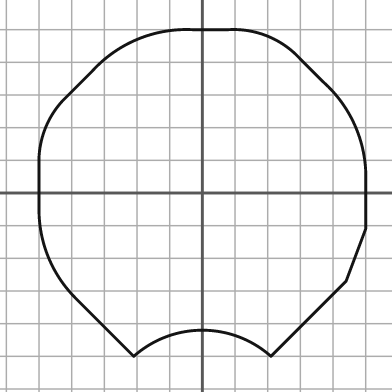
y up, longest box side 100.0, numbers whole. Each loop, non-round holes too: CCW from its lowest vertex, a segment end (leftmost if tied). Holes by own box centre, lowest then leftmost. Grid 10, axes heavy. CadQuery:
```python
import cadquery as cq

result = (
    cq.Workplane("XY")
    .moveTo(-21.0, -50.0)
    .threePointArc((0.0, -42.0), (21.0, -50.0))
    .lineTo(44.0, -27.0)
    .lineTo(50.0, -11.0)
    .lineTo(50.0, 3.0)
    .threePointArc((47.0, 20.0), (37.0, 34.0))
    .lineTo(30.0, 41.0)
    .threePointArc((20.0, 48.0), (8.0, 50.0))
    .lineTo(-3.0, 50.0)
    .threePointArc((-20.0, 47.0), (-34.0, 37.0))
    .lineTo(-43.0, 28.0)
    .threePointArc((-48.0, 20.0), (-50.0, 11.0))
    .lineTo(-50.0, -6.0)
    .threePointArc((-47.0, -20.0), (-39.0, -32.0))
    .close()
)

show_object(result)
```